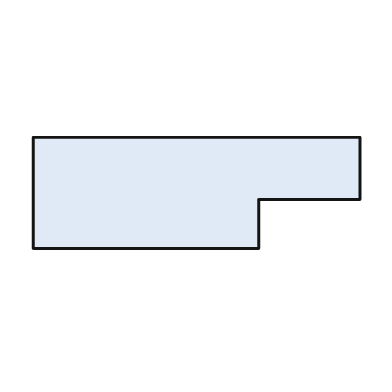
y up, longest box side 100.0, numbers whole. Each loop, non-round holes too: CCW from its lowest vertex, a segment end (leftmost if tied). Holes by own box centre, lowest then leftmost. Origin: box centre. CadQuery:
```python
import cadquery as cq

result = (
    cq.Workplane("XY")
    .moveTo(-50.0, -17.0)
    .lineTo(19.0, -17.0)
    .lineTo(19.0, -2.0)
    .lineTo(50.0, -2.0)
    .lineTo(50.0, 17.0)
    .lineTo(-50.0, 17.0)
    .close()
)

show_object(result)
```